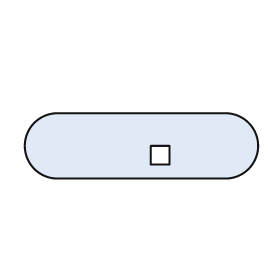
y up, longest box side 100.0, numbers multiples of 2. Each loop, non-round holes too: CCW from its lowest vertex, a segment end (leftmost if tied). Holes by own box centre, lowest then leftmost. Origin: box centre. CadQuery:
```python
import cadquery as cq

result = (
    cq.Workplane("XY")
    .moveTo(-36.0, -14.0)
    .lineTo(36.0, -14.0)
    .threePointArc((50.0, 0.0), (36.0, 14.0))
    .lineTo(-36.0, 14.0)
    .threePointArc((-50.0, 0.0), (-36.0, -14.0))
    .close()
    .moveTo(4.0, -8.0)
    .lineTo(12.0, -8.0)
    .lineTo(12.0, 0.0)
    .lineTo(4.0, 0.0)
    .close()
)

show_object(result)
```